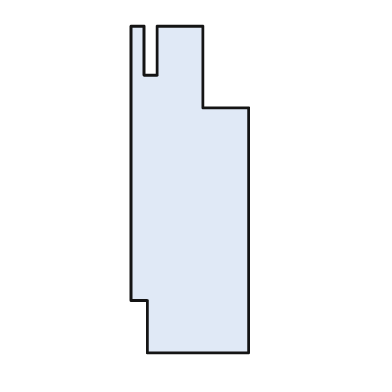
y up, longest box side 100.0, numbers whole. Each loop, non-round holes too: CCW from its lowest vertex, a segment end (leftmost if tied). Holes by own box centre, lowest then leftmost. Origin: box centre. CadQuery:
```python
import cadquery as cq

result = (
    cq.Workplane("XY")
    .moveTo(-13.0, -50.0)
    .lineTo(18.0, -50.0)
    .lineTo(18.0, 25.0)
    .lineTo(4.0, 25.0)
    .lineTo(4.0, 50.0)
    .lineTo(-10.0, 50.0)
    .lineTo(-10.0, 35.0)
    .lineTo(-14.0, 35.0)
    .lineTo(-14.0, 50.0)
    .lineTo(-18.0, 50.0)
    .lineTo(-18.0, -34.0)
    .lineTo(-13.0, -34.0)
    .close()
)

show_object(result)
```